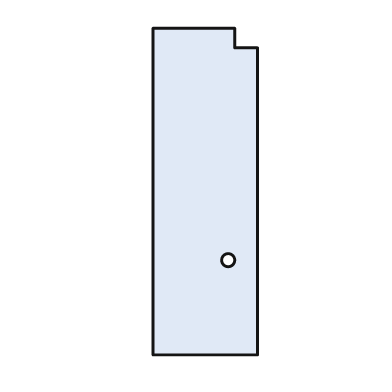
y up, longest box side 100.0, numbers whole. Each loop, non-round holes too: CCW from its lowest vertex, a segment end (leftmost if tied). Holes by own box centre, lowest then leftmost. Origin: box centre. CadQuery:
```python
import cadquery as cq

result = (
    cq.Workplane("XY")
    .moveTo(-16.0, -50.0)
    .lineTo(16.0, -50.0)
    .lineTo(16.0, 44.0)
    .lineTo(9.0, 44.0)
    .lineTo(9.0, 50.0)
    .lineTo(-16.0, 50.0)
    .close()
    .moveTo(7.0, -21.0)
    .circle(2.0)
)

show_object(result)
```